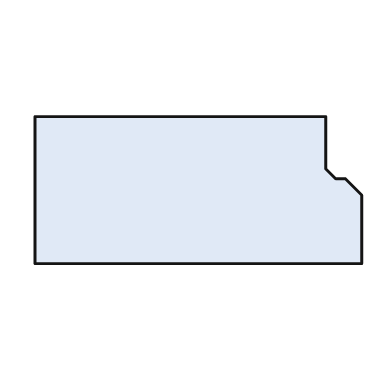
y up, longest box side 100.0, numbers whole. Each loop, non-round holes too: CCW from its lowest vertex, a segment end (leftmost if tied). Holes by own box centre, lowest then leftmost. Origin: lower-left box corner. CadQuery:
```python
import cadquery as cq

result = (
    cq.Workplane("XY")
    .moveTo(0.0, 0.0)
    .lineTo(100.0, 0.0)
    .lineTo(100.0, 21.0)
    .lineTo(95.0, 26.0)
    .lineTo(92.0, 26.0)
    .lineTo(89.0, 29.0)
    .lineTo(89.0, 45.0)
    .lineTo(0.0, 45.0)
    .close()
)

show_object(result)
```